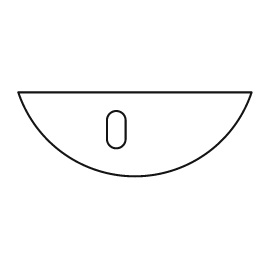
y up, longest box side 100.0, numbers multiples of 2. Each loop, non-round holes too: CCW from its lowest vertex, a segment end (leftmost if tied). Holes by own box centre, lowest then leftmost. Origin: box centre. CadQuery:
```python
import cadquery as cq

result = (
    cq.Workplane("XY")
    .moveTo(-50.0, 18.0)
    .threePointArc((0.0, -18.0), (50.0, 18.0))
    .close()
    .moveTo(-12.0, -2.0)
    .threePointArc((-8.0, -6.0), (-4.0, -2.0))
    .lineTo(-4.0, 6.0)
    .threePointArc((-8.0, 10.0), (-12.0, 6.0))
    .close()
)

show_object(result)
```